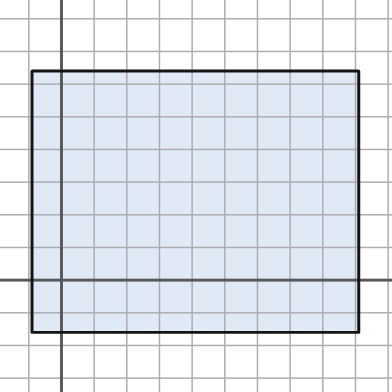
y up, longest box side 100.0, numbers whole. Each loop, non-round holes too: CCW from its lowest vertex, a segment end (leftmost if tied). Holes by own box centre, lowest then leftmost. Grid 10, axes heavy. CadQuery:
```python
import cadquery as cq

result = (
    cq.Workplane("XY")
    .moveTo(-9.0, -16.0)
    .lineTo(91.0, -16.0)
    .lineTo(91.0, 64.0)
    .lineTo(-9.0, 64.0)
    .close()
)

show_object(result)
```